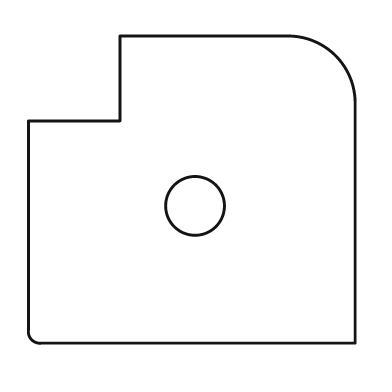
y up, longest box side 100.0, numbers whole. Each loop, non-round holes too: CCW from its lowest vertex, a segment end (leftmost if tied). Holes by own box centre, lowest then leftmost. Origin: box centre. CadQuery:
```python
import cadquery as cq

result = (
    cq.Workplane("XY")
    .moveTo(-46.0, -47.0)
    .lineTo(50.0, -47.0)
    .lineTo(50.0, 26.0)
    .threePointArc((44.0, 41.0), (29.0, 47.0))
    .lineTo(-22.0, 47.0)
    .lineTo(-22.0, 21.0)
    .lineTo(-50.0, 21.0)
    .lineTo(-50.0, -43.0)
    .threePointArc((-49.0, -46.0), (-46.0, -47.0))
    .close()
    .moveTo(1.0, -5.0)
    .circle(9.0)
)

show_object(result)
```